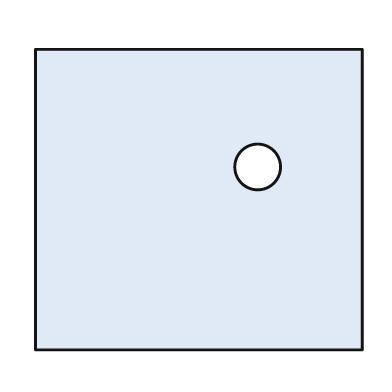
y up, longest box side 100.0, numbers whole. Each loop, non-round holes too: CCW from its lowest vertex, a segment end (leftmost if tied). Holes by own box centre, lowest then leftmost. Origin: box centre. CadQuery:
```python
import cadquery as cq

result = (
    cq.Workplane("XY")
    .moveTo(-50.0, -46.0)
    .lineTo(50.0, -46.0)
    .lineTo(50.0, 46.0)
    .lineTo(-50.0, 46.0)
    .close()
    .moveTo(18.0, 10.0)
    .circle(7.0)
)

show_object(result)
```